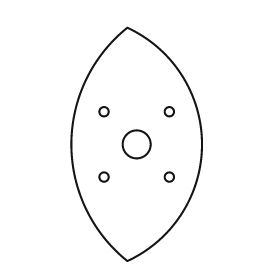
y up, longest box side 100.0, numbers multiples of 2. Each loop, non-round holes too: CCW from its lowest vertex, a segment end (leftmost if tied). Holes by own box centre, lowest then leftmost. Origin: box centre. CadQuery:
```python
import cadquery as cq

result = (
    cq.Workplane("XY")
    .moveTo(-4.0, -50.0)
    .threePointArc((28.0, 0.0), (-4.0, 50.0))
    .threePointArc((-28.0, 0.0), (-4.0, -50.0))
    .close()
    .moveTo(-14.0, -14.0)
    .circle(2.0)
    .moveTo(14.0, -14.0)
    .circle(2.0)
    .moveTo(0.0, 0.0)
    .circle(6.0)
    .moveTo(-14.0, 14.0)
    .circle(2.0)
    .moveTo(14.0, 14.0)
    .circle(2.0)
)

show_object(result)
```